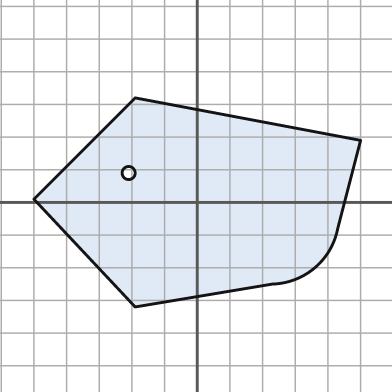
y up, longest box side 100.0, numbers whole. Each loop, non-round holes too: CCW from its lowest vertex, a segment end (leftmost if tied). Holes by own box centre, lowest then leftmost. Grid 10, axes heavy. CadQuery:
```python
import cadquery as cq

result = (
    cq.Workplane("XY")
    .moveTo(-19.0, -32.0)
    .lineTo(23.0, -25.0)
    .threePointArc((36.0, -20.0), (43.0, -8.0))
    .lineTo(50.0, 19.0)
    .lineTo(-19.0, 32.0)
    .lineTo(-50.0, 1.0)
    .close()
    .moveTo(-21.0, 9.0)
    .circle(2.0)
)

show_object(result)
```